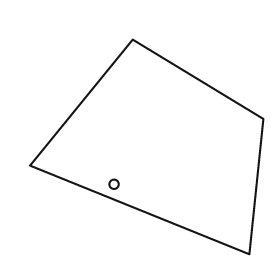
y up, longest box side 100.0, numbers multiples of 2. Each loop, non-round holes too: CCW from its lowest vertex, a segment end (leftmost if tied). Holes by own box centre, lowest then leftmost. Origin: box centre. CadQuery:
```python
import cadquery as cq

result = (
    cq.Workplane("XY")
    .moveTo(44.0, -46.0)
    .lineTo(50.0, 12.0)
    .lineTo(-6.0, 46.0)
    .lineTo(-50.0, -8.0)
    .close()
    .moveTo(-14.0, -16.0)
    .circle(2.0)
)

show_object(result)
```